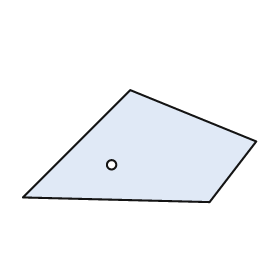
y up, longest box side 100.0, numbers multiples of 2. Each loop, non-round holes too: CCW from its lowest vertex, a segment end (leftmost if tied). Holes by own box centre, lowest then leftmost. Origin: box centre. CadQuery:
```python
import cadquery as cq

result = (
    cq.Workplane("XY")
    .moveTo(30.0, -24.0)
    .lineTo(50.0, 2.0)
    .lineTo(-4.0, 24.0)
    .lineTo(-50.0, -22.0)
    .close()
    .moveTo(-12.0, -8.0)
    .circle(2.0)
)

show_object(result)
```